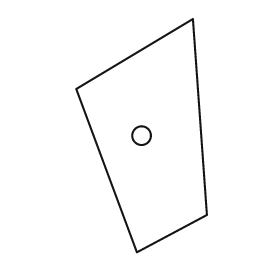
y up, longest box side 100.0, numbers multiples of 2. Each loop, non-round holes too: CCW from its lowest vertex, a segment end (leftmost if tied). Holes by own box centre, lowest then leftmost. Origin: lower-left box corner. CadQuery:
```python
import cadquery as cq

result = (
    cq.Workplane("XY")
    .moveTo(26.0, 0.0)
    .lineTo(56.0, 16.0)
    .lineTo(50.0, 100.0)
    .lineTo(0.0, 70.0)
    .close()
    .moveTo(28.0, 50.0)
    .circle(4.0)
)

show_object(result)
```